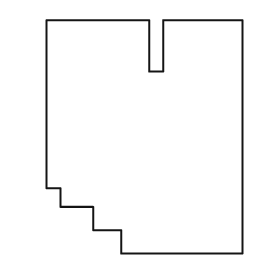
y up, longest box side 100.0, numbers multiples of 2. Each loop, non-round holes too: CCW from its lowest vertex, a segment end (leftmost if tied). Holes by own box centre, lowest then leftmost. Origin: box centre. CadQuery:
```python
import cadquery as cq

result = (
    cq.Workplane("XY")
    .moveTo(-10.0, -50.0)
    .lineTo(42.0, -50.0)
    .lineTo(42.0, 50.0)
    .lineTo(8.0, 50.0)
    .lineTo(8.0, 28.0)
    .lineTo(2.0, 28.0)
    .lineTo(2.0, 50.0)
    .lineTo(-42.0, 50.0)
    .lineTo(-42.0, -22.0)
    .lineTo(-36.0, -22.0)
    .lineTo(-36.0, -30.0)
    .lineTo(-22.0, -30.0)
    .lineTo(-22.0, -40.0)
    .lineTo(-10.0, -40.0)
    .close()
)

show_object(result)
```